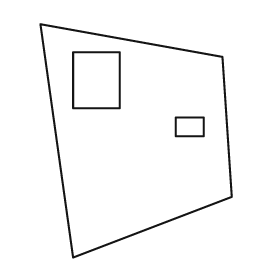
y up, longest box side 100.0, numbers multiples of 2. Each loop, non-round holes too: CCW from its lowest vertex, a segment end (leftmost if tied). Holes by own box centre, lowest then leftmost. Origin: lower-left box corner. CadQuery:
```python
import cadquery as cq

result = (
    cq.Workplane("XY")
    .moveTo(14.0, 0.0)
    .lineTo(82.0, 26.0)
    .lineTo(78.0, 86.0)
    .lineTo(0.0, 100.0)
    .close()
    .moveTo(58.0, 52.0)
    .lineTo(70.0, 52.0)
    .lineTo(70.0, 60.0)
    .lineTo(58.0, 60.0)
    .close()
    .moveTo(14.0, 64.0)
    .lineTo(34.0, 64.0)
    .lineTo(34.0, 88.0)
    .lineTo(14.0, 88.0)
    .close()
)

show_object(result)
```